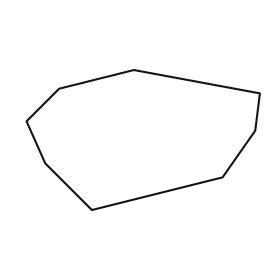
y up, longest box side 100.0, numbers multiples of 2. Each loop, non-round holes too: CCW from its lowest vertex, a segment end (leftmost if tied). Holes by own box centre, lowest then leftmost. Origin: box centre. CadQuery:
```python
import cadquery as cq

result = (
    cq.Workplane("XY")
    .moveTo(-22.0, -30.0)
    .lineTo(34.0, -16.0)
    .lineTo(48.0, 4.0)
    .lineTo(50.0, 20.0)
    .lineTo(-4.0, 30.0)
    .lineTo(-36.0, 22.0)
    .lineTo(-50.0, 8.0)
    .lineTo(-42.0, -10.0)
    .close()
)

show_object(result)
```